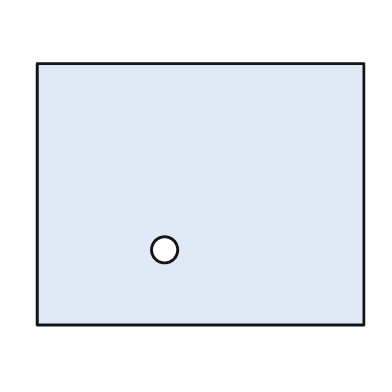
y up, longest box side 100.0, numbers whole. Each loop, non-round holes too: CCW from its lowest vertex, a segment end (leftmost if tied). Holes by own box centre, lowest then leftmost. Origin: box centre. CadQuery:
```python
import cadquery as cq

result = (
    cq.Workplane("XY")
    .moveTo(-50.0, -40.0)
    .lineTo(50.0, -40.0)
    .lineTo(50.0, 40.0)
    .lineTo(-50.0, 40.0)
    .close()
    .moveTo(-11.0, -17.0)
    .circle(4.0)
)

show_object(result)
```